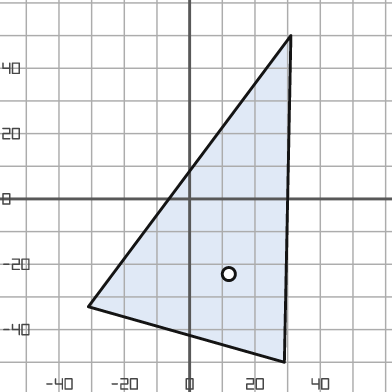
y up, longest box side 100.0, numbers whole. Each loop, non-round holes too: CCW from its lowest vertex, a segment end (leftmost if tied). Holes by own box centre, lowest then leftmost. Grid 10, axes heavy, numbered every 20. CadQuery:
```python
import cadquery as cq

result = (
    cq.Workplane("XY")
    .moveTo(29.0, -50.0)
    .lineTo(31.0, 50.0)
    .lineTo(-31.0, -33.0)
    .close()
    .moveTo(12.0, -23.0)
    .circle(2.0)
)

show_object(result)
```